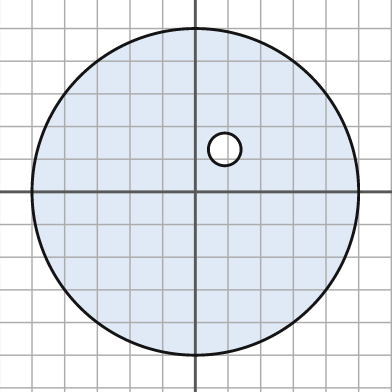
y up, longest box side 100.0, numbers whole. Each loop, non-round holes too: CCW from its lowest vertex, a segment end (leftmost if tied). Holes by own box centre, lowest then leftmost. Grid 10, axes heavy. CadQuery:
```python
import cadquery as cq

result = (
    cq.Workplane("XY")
    .moveTo(0.0, 0.0)
    .circle(50.0)
    .moveTo(9.0, 13.0)
    .circle(5.0)
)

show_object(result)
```